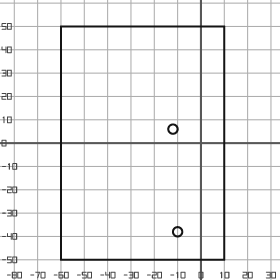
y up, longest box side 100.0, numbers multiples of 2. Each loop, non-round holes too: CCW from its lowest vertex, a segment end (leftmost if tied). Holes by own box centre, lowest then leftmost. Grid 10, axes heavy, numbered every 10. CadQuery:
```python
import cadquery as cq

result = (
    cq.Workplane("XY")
    .moveTo(-60.0, -50.0)
    .lineTo(10.0, -50.0)
    .lineTo(10.0, 50.0)
    .lineTo(-60.0, 50.0)
    .close()
    .moveTo(-10.0, -38.0)
    .circle(2.0)
    .moveTo(-12.0, 6.0)
    .circle(2.0)
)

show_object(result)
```